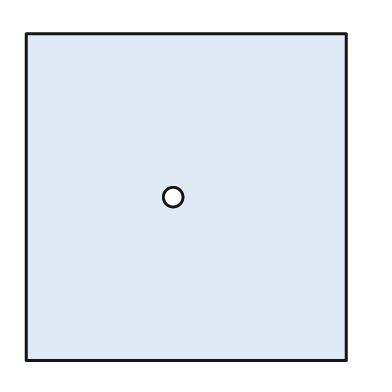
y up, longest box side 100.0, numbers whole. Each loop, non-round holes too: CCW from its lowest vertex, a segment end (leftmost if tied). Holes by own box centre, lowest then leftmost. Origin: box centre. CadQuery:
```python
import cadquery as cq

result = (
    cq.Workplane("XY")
    .moveTo(-49.0, -50.0)
    .lineTo(49.0, -50.0)
    .lineTo(49.0, 50.0)
    .lineTo(-49.0, 50.0)
    .close()
    .moveTo(-4.0, 0.0)
    .circle(3.0)
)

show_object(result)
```